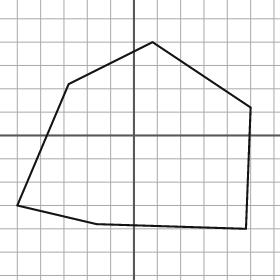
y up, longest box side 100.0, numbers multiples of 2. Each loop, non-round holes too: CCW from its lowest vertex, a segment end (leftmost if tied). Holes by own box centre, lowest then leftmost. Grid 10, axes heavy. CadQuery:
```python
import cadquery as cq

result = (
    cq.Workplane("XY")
    .moveTo(48.0, -40.0)
    .lineTo(50.0, 12.0)
    .lineTo(8.0, 40.0)
    .lineTo(-28.0, 22.0)
    .lineTo(-50.0, -30.0)
    .lineTo(-16.0, -38.0)
    .close()
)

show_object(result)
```